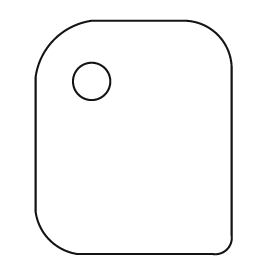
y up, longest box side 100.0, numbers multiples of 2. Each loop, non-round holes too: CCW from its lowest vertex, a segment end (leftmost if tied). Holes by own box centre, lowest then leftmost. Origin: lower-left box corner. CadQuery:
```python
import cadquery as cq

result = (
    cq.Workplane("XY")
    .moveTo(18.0, 0.0)
    .lineTo(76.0, 0.0)
    .threePointArc((82.0, 2.0), (84.0, 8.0))
    .lineTo(84.0, 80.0)
    .threePointArc((78.0, 94.0), (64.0, 100.0))
    .lineTo(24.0, 100.0)
    .threePointArc((8.0, 92.0), (0.0, 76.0))
    .lineTo(0.0, 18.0)
    .threePointArc((6.0, 6.0), (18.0, 0.0))
    .close()
    .moveTo(24.0, 74.0)
    .circle(8.0)
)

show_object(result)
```